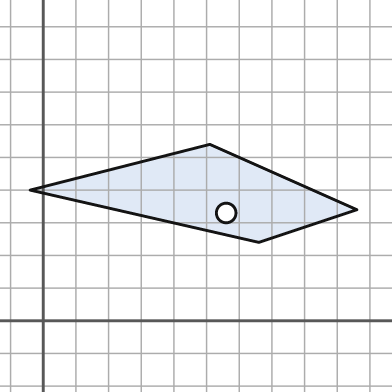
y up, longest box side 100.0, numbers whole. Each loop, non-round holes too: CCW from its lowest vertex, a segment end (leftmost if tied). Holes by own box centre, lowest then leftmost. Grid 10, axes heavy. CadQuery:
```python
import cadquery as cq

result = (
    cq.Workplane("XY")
    .moveTo(66.0, 24.0)
    .lineTo(96.0, 34.0)
    .lineTo(51.0, 54.0)
    .lineTo(-4.0, 40.0)
    .close()
    .moveTo(56.0, 33.0)
    .circle(3.0)
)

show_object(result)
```